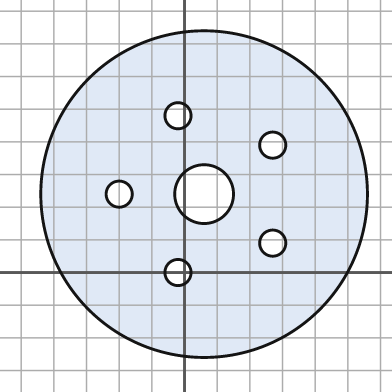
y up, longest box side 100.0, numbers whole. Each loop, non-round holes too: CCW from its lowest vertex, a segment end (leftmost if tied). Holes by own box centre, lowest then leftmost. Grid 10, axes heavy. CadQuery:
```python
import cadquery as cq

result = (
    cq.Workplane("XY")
    .moveTo(6.0, 24.0)
    .circle(50.0)
    .moveTo(-2.0, 0.0)
    .circle(4.0)
    .moveTo(27.0, 9.0)
    .circle(4.0)
    .moveTo(-20.0, 24.0)
    .circle(4.0)
    .moveTo(6.0, 24.0)
    .circle(9.0)
    .moveTo(27.0, 39.0)
    .circle(4.0)
    .moveTo(-2.0, 48.0)
    .circle(4.0)
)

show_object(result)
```